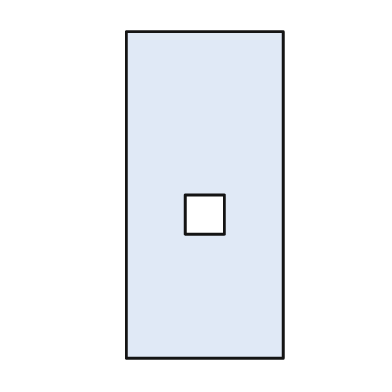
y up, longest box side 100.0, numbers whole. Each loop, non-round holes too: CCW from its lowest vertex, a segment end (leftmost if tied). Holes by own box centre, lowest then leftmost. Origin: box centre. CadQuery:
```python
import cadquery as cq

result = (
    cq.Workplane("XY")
    .moveTo(-24.0, -50.0)
    .lineTo(24.0, -50.0)
    .lineTo(24.0, 50.0)
    .lineTo(-24.0, 50.0)
    .close()
    .moveTo(-6.0, -12.0)
    .lineTo(6.0, -12.0)
    .lineTo(6.0, 0.0)
    .lineTo(-6.0, 0.0)
    .close()
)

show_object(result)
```